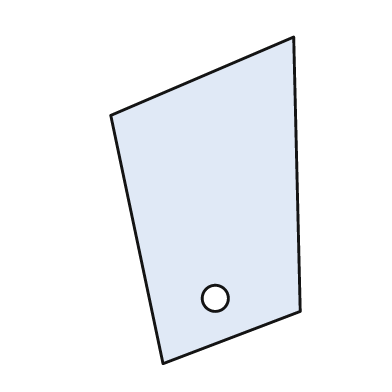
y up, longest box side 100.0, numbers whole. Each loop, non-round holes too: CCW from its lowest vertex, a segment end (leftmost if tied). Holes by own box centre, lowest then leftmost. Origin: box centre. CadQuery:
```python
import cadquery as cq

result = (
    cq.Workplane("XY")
    .moveTo(-13.0, -50.0)
    .lineTo(29.0, -34.0)
    .lineTo(27.0, 50.0)
    .lineTo(-29.0, 26.0)
    .close()
    .moveTo(3.0, -30.0)
    .circle(4.0)
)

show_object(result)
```